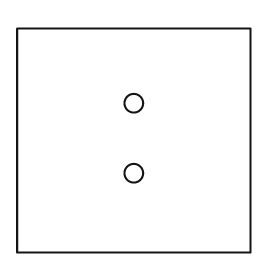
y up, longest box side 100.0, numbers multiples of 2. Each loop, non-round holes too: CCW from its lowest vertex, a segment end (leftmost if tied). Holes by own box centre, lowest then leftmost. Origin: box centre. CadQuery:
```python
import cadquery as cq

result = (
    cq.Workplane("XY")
    .moveTo(-50.0, -48.0)
    .lineTo(50.0, -48.0)
    .lineTo(50.0, 48.0)
    .lineTo(-50.0, 48.0)
    .close()
    .moveTo(0.0, -14.0)
    .circle(4.0)
    .moveTo(0.0, 16.0)
    .circle(4.0)
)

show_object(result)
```